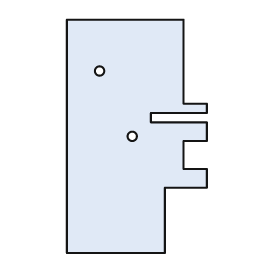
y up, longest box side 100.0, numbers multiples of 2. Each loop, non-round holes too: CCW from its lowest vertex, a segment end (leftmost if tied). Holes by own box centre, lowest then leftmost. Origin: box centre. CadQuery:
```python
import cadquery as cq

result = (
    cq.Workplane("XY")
    .moveTo(-30.0, -50.0)
    .lineTo(12.0, -50.0)
    .lineTo(12.0, -22.0)
    .lineTo(30.0, -22.0)
    .lineTo(30.0, -14.0)
    .lineTo(20.0, -14.0)
    .lineTo(20.0, -2.0)
    .lineTo(30.0, -2.0)
    .lineTo(30.0, 6.0)
    .lineTo(6.0, 6.0)
    .lineTo(6.0, 10.0)
    .lineTo(30.0, 10.0)
    .lineTo(30.0, 14.0)
    .lineTo(20.0, 14.0)
    .lineTo(20.0, 50.0)
    .lineTo(-30.0, 50.0)
    .close()
    .moveTo(-2.0, 0.0)
    .circle(2.0)
    .moveTo(-16.0, 28.0)
    .circle(2.0)
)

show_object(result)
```